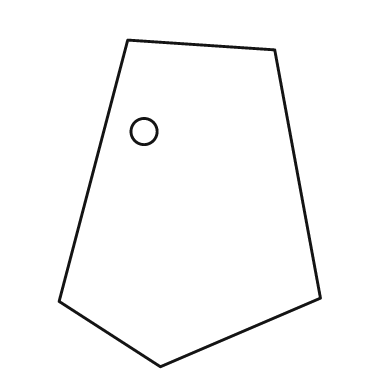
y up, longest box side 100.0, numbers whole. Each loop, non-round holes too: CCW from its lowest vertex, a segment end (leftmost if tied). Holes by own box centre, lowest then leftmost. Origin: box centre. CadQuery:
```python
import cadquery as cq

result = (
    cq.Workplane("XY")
    .moveTo(-9.0, -50.0)
    .lineTo(40.0, -29.0)
    .lineTo(26.0, 47.0)
    .lineTo(-19.0, 50.0)
    .lineTo(-40.0, -30.0)
    .close()
    .moveTo(-14.0, 22.0)
    .circle(4.0)
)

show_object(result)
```